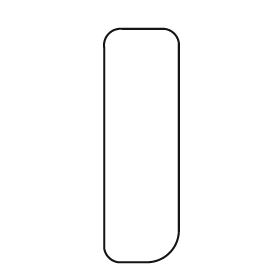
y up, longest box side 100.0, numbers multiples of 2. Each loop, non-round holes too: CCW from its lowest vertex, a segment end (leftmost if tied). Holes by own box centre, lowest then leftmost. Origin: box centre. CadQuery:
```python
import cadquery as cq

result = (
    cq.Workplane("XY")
    .moveTo(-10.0, -50.0)
    .lineTo(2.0, -50.0)
    .threePointArc((12.0, -46.0), (16.0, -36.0))
    .lineTo(16.0, 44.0)
    .threePointArc((14.0, 48.0), (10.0, 50.0))
    .lineTo(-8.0, 50.0)
    .threePointArc((-14.0, 48.0), (-16.0, 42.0))
    .lineTo(-16.0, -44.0)
    .threePointArc((-14.0, -48.0), (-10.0, -50.0))
    .close()
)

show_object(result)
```